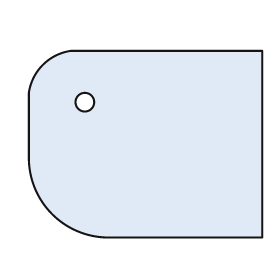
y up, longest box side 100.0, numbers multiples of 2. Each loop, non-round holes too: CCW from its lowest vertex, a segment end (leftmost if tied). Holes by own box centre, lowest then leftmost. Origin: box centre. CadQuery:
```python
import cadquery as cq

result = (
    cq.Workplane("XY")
    .moveTo(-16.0, -40.0)
    .lineTo(50.0, -40.0)
    .lineTo(50.0, 40.0)
    .lineTo(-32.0, 40.0)
    .threePointArc((-44.0, 34.0), (-50.0, 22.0))
    .lineTo(-50.0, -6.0)
    .threePointArc((-40.0, -30.0), (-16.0, -40.0))
    .close()
    .moveTo(-26.0, 18.0)
    .circle(4.0)
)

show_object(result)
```